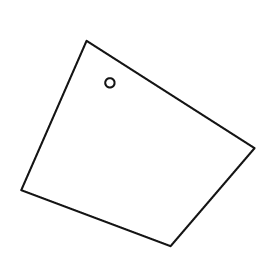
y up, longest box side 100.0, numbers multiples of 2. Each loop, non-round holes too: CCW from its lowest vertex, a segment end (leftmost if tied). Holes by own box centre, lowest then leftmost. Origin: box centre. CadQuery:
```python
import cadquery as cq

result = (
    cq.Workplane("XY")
    .moveTo(14.0, -44.0)
    .lineTo(50.0, -2.0)
    .lineTo(-22.0, 44.0)
    .lineTo(-50.0, -20.0)
    .close()
    .moveTo(-12.0, 26.0)
    .circle(2.0)
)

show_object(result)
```